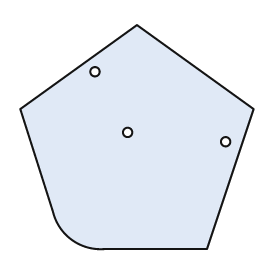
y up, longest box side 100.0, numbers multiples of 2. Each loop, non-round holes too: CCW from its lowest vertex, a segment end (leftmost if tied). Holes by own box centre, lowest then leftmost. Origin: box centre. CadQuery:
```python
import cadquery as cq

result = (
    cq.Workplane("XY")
    .moveTo(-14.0, -48.0)
    .lineTo(30.0, -48.0)
    .lineTo(50.0, 12.0)
    .lineTo(0.0, 48.0)
    .lineTo(-50.0, 12.0)
    .lineTo(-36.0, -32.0)
    .threePointArc((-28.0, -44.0), (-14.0, -48.0))
    .close()
    .moveTo(38.0, -2.0)
    .circle(2.0)
    .moveTo(-4.0, 2.0)
    .circle(2.0)
    .moveTo(-18.0, 28.0)
    .circle(2.0)
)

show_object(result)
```